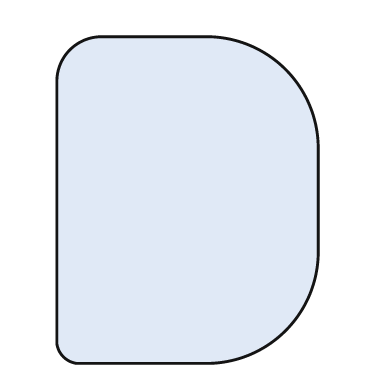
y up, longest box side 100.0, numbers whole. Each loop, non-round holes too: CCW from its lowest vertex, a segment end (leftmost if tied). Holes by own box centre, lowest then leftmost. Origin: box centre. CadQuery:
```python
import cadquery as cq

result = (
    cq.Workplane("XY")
    .moveTo(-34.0, -50.0)
    .lineTo(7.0, -50.0)
    .threePointArc((30.0, -40.0), (40.0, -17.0))
    .lineTo(40.0, 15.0)
    .threePointArc((30.0, 40.0), (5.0, 50.0))
    .lineTo(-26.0, 50.0)
    .threePointArc((-36.0, 46.0), (-40.0, 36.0))
    .lineTo(-40.0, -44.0)
    .threePointArc((-38.0, -48.0), (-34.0, -50.0))
    .close()
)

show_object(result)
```